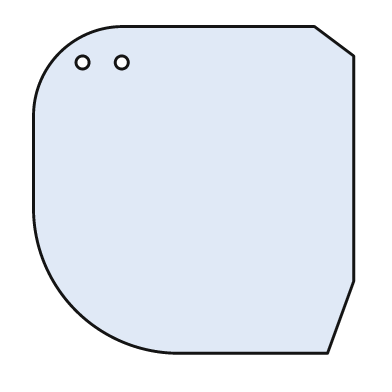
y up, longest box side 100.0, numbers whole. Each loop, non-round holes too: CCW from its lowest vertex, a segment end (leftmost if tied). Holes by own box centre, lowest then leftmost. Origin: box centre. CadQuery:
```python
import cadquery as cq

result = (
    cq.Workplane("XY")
    .moveTo(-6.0, -50.0)
    .lineTo(41.0, -50.0)
    .lineTo(49.0, -28.0)
    .lineTo(49.0, 41.0)
    .lineTo(37.0, 50.0)
    .lineTo(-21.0, 50.0)
    .threePointArc((-41.0, 42.0), (-49.0, 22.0))
    .lineTo(-49.0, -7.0)
    .threePointArc((-36.0, -37.0), (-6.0, -50.0))
    .close()
    .moveTo(-34.0, 39.0)
    .circle(2.0)
    .moveTo(-22.0, 39.0)
    .circle(2.0)
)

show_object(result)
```